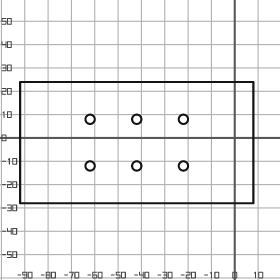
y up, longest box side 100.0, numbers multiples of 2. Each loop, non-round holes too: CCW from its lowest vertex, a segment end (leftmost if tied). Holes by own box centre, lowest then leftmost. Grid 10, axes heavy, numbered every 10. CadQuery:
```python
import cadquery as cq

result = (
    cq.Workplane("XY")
    .moveTo(-92.0, -28.0)
    .lineTo(8.0, -28.0)
    .lineTo(8.0, 24.0)
    .lineTo(-92.0, 24.0)
    .close()
    .moveTo(-62.0, -12.0)
    .circle(2.0)
    .moveTo(-42.0, -12.0)
    .circle(2.0)
    .moveTo(-22.0, -12.0)
    .circle(2.0)
    .moveTo(-62.0, 8.0)
    .circle(2.0)
    .moveTo(-42.0, 8.0)
    .circle(2.0)
    .moveTo(-22.0, 8.0)
    .circle(2.0)
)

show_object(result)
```